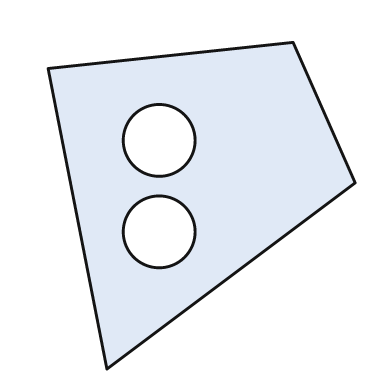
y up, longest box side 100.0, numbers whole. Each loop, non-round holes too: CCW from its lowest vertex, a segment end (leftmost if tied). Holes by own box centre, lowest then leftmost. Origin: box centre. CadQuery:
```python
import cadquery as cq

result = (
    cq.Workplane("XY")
    .moveTo(-29.0, -50.0)
    .lineTo(47.0, 7.0)
    .lineTo(28.0, 50.0)
    .lineTo(-47.0, 42.0)
    .close()
    .moveTo(-13.0, -8.0)
    .circle(11.0)
    .moveTo(-13.0, 20.0)
    .circle(11.0)
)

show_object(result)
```